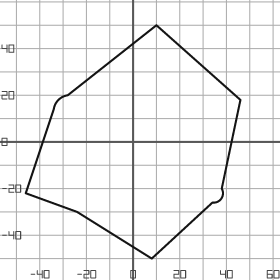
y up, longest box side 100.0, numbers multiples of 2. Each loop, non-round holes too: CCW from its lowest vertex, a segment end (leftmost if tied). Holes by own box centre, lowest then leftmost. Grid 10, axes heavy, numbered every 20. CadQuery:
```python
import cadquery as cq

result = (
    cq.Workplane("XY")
    .moveTo(8.0, -50.0)
    .lineTo(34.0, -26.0)
    .threePointArc((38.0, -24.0), (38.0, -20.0))
    .lineTo(46.0, 18.0)
    .lineTo(10.0, 50.0)
    .lineTo(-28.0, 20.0)
    .threePointArc((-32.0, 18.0), (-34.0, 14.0))
    .lineTo(-46.0, -22.0)
    .lineTo(-24.0, -30.0)
    .close()
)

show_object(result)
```